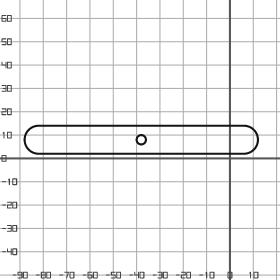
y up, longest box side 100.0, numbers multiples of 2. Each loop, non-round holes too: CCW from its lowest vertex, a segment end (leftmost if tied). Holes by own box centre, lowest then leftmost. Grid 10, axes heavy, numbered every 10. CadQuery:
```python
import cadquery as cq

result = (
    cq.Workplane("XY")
    .moveTo(-82.0, 2.0)
    .lineTo(6.0, 2.0)
    .threePointArc((12.0, 8.0), (6.0, 14.0))
    .lineTo(-82.0, 14.0)
    .threePointArc((-88.0, 8.0), (-82.0, 2.0))
    .close()
    .moveTo(-38.0, 8.0)
    .circle(2.0)
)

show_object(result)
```